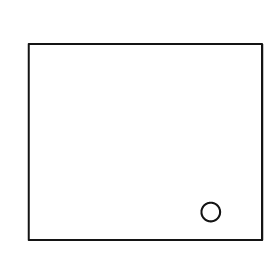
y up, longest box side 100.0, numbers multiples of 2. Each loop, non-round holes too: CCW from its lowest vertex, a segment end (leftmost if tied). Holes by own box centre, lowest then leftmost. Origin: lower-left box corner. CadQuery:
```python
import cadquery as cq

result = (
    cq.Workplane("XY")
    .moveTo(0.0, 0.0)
    .lineTo(100.0, 0.0)
    .lineTo(100.0, 84.0)
    .lineTo(0.0, 84.0)
    .close()
    .moveTo(78.0, 12.0)
    .circle(4.0)
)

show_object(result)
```